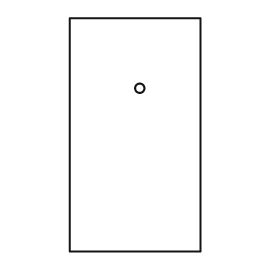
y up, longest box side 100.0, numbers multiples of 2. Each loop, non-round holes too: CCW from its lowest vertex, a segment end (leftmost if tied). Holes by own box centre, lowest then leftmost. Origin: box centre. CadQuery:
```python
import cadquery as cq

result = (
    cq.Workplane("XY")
    .moveTo(-28.0, -50.0)
    .lineTo(28.0, -50.0)
    .lineTo(28.0, 50.0)
    .lineTo(-28.0, 50.0)
    .close()
    .moveTo(2.0, 20.0)
    .circle(2.0)
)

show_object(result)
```